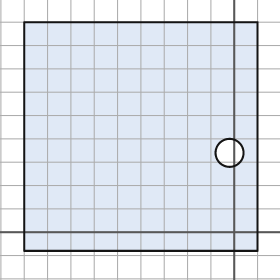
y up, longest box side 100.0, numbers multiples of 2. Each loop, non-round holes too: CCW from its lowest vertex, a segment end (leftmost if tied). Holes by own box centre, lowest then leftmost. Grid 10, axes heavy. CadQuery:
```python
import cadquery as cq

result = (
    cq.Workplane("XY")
    .moveTo(-90.0, -8.0)
    .lineTo(10.0, -8.0)
    .lineTo(10.0, 90.0)
    .lineTo(-90.0, 90.0)
    .close()
    .moveTo(-2.0, 34.0)
    .circle(6.0)
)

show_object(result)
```